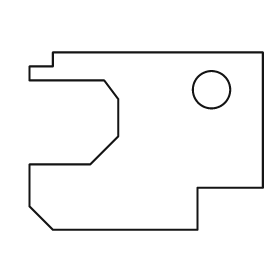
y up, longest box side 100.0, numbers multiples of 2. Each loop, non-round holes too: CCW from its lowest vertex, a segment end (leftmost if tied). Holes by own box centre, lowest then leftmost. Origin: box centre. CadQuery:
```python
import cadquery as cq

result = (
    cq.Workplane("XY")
    .moveTo(-40.0, -38.0)
    .lineTo(22.0, -38.0)
    .lineTo(22.0, -20.0)
    .lineTo(50.0, -20.0)
    .lineTo(50.0, 38.0)
    .lineTo(-40.0, 38.0)
    .lineTo(-40.0, 32.0)
    .lineTo(-50.0, 32.0)
    .lineTo(-50.0, 26.0)
    .lineTo(-18.0, 26.0)
    .lineTo(-12.0, 18.0)
    .lineTo(-12.0, 2.0)
    .lineTo(-24.0, -10.0)
    .lineTo(-50.0, -10.0)
    .lineTo(-50.0, -28.0)
    .close()
    .moveTo(28.0, 22.0)
    .circle(8.0)
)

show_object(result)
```